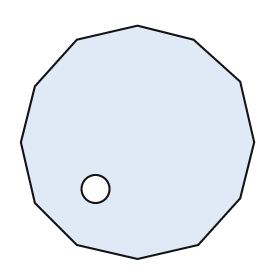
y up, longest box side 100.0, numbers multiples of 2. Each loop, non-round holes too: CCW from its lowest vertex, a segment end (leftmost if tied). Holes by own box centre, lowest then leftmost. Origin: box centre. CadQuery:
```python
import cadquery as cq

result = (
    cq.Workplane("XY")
    .moveTo(0.0, -50.0)
    .lineTo(26.0, -44.0)
    .lineTo(44.0, -24.0)
    .lineTo(50.0, 0.0)
    .lineTo(44.0, 26.0)
    .lineTo(24.0, 44.0)
    .lineTo(0.0, 50.0)
    .lineTo(-26.0, 44.0)
    .lineTo(-44.0, 24.0)
    .lineTo(-50.0, 0.0)
    .lineTo(-44.0, -26.0)
    .lineTo(-26.0, -44.0)
    .close()
    .moveTo(-18.0, -20.0)
    .circle(6.0)
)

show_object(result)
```